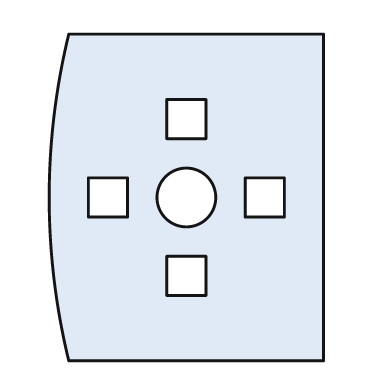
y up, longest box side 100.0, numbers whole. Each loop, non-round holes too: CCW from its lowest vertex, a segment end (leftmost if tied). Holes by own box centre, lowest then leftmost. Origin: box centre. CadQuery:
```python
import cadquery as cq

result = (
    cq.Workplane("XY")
    .moveTo(-36.0, -50.0)
    .lineTo(42.0, -50.0)
    .lineTo(42.0, 50.0)
    .lineTo(-36.0, 50.0)
    .threePointArc((-42.0, 0.0), (-36.0, -50.0))
    .close()
    .moveTo(-6.0, -30.0)
    .lineTo(6.0, -30.0)
    .lineTo(6.0, -18.0)
    .lineTo(-6.0, -18.0)
    .close()
    .moveTo(-30.0, -6.0)
    .lineTo(-18.0, -6.0)
    .lineTo(-18.0, 6.0)
    .lineTo(-30.0, 6.0)
    .close()
    .moveTo(0.0, 0.0)
    .circle(9.0)
    .moveTo(18.0, -6.0)
    .lineTo(30.0, -6.0)
    .lineTo(30.0, 6.0)
    .lineTo(18.0, 6.0)
    .close()
    .moveTo(-6.0, 18.0)
    .lineTo(6.0, 18.0)
    .lineTo(6.0, 30.0)
    .lineTo(-6.0, 30.0)
    .close()
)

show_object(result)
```